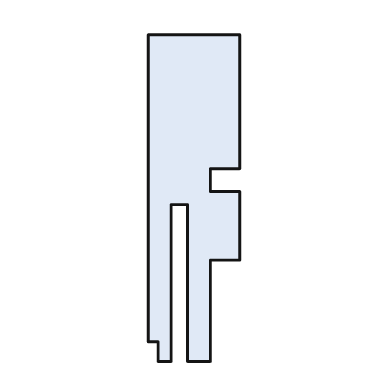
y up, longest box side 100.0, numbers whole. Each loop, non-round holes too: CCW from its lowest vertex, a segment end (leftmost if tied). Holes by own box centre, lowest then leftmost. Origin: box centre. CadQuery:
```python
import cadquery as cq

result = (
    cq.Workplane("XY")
    .moveTo(-11.0, -50.0)
    .lineTo(-7.0, -50.0)
    .lineTo(-7.0, -2.0)
    .lineTo(-2.0, -2.0)
    .lineTo(-2.0, -50.0)
    .lineTo(5.0, -50.0)
    .lineTo(5.0, -19.0)
    .lineTo(14.0, -19.0)
    .lineTo(14.0, 2.0)
    .lineTo(5.0, 2.0)
    .lineTo(5.0, 9.0)
    .lineTo(14.0, 9.0)
    .lineTo(14.0, 50.0)
    .lineTo(-14.0, 50.0)
    .lineTo(-14.0, -44.0)
    .lineTo(-11.0, -44.0)
    .close()
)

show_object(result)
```